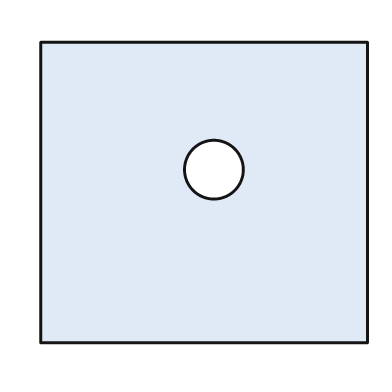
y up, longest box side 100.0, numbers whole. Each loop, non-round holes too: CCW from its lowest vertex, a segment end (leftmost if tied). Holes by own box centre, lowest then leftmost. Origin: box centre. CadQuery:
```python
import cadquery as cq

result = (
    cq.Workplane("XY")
    .moveTo(-50.0, -46.0)
    .lineTo(50.0, -46.0)
    .lineTo(50.0, 46.0)
    .lineTo(-50.0, 46.0)
    .close()
    .moveTo(3.0, 7.0)
    .circle(9.0)
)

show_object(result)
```